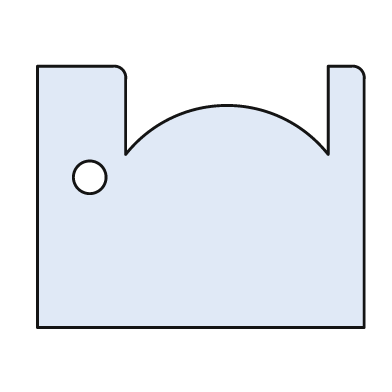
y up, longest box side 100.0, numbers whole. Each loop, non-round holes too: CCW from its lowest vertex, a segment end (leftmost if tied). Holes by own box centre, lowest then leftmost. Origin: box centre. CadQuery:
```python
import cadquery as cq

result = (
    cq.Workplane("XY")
    .moveTo(-50.0, -40.0)
    .lineTo(50.0, -40.0)
    .lineTo(50.0, 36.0)
    .threePointArc((49.0, 39.0), (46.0, 40.0))
    .lineTo(39.0, 40.0)
    .lineTo(39.0, 13.0)
    .threePointArc((8.0, 28.0), (-23.0, 13.0))
    .lineTo(-23.0, 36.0)
    .threePointArc((-24.0, 39.0), (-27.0, 40.0))
    .lineTo(-50.0, 40.0)
    .close()
    .moveTo(-34.0, 6.0)
    .circle(5.0)
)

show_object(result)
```